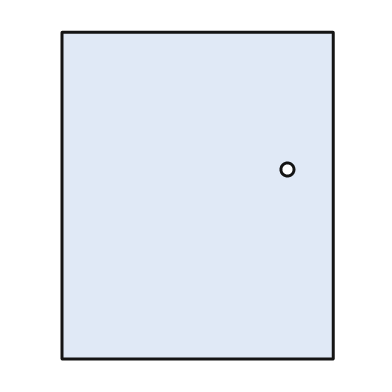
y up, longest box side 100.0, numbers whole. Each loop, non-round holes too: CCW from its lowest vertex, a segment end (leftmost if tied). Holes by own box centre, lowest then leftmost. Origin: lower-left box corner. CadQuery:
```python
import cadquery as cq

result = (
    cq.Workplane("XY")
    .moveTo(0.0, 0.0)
    .lineTo(83.0, 0.0)
    .lineTo(83.0, 100.0)
    .lineTo(0.0, 100.0)
    .close()
    .moveTo(69.0, 58.0)
    .circle(2.0)
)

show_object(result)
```